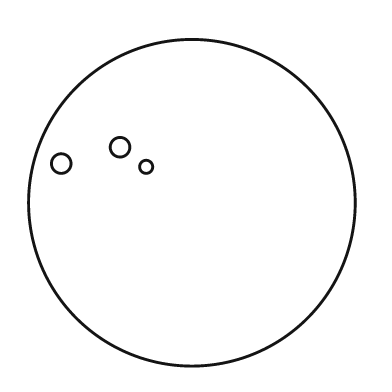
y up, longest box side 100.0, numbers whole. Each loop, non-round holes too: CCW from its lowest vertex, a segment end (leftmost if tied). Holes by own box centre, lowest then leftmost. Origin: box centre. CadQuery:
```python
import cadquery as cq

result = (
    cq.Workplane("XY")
    .moveTo(0.0, 0.0)
    .circle(50.0)
    .moveTo(-14.0, 11.0)
    .circle(2.0)
    .moveTo(-40.0, 12.0)
    .circle(3.0)
    .moveTo(-22.0, 17.0)
    .circle(3.0)
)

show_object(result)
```